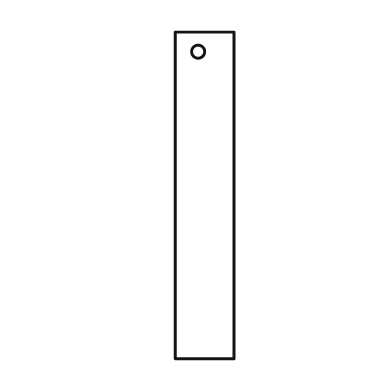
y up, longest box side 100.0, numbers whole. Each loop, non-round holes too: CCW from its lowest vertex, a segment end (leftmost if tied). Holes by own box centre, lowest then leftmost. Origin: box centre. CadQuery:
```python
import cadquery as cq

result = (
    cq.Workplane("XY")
    .moveTo(-9.0, -50.0)
    .lineTo(9.0, -50.0)
    .lineTo(9.0, 50.0)
    .lineTo(-9.0, 50.0)
    .close()
    .moveTo(-2.0, 44.0)
    .circle(2.0)
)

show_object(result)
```